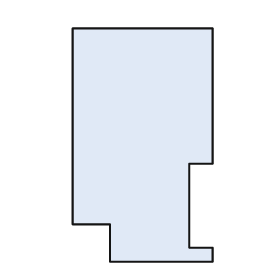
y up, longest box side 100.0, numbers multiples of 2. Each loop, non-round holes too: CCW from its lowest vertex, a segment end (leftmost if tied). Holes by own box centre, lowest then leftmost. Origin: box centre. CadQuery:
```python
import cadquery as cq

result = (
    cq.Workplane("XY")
    .moveTo(-14.0, -50.0)
    .lineTo(30.0, -50.0)
    .lineTo(30.0, -44.0)
    .lineTo(20.0, -44.0)
    .lineTo(20.0, -8.0)
    .lineTo(30.0, -8.0)
    .lineTo(30.0, 50.0)
    .lineTo(-30.0, 50.0)
    .lineTo(-30.0, -34.0)
    .lineTo(-14.0, -34.0)
    .close()
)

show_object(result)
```